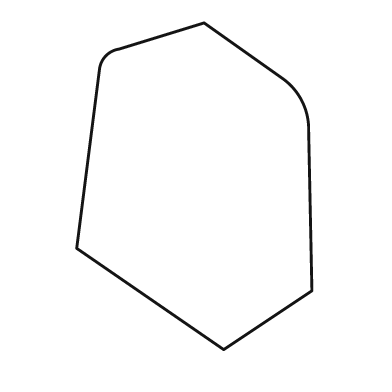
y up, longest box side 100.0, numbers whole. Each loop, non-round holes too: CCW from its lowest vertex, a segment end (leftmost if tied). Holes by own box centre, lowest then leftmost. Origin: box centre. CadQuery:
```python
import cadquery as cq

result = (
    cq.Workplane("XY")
    .moveTo(9.0, -50.0)
    .lineTo(36.0, -32.0)
    .lineTo(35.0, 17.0)
    .threePointArc((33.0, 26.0), (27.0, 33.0))
    .lineTo(3.0, 50.0)
    .lineTo(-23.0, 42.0)
    .threePointArc((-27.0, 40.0), (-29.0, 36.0))
    .lineTo(-36.0, -19.0)
    .close()
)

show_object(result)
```